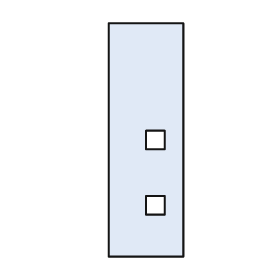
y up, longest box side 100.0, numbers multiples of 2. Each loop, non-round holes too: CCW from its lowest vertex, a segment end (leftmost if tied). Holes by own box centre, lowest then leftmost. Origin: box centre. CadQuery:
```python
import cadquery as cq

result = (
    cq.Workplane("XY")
    .moveTo(-16.0, -50.0)
    .lineTo(16.0, -50.0)
    .lineTo(16.0, 50.0)
    .lineTo(-16.0, 50.0)
    .close()
    .moveTo(0.0, -32.0)
    .lineTo(8.0, -32.0)
    .lineTo(8.0, -24.0)
    .lineTo(0.0, -24.0)
    .close()
    .moveTo(0.0, -4.0)
    .lineTo(8.0, -4.0)
    .lineTo(8.0, 4.0)
    .lineTo(0.0, 4.0)
    .close()
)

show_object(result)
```